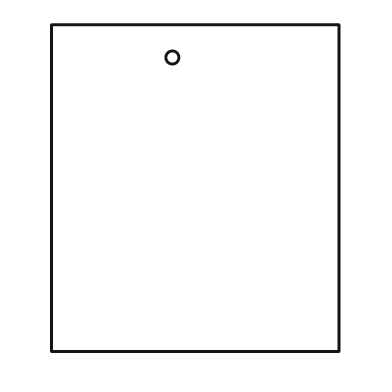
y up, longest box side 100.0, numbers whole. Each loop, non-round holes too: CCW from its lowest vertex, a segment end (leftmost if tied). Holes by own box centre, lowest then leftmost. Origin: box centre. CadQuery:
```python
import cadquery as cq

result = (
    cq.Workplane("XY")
    .moveTo(-44.0, -50.0)
    .lineTo(44.0, -50.0)
    .lineTo(44.0, 50.0)
    .lineTo(-44.0, 50.0)
    .close()
    .moveTo(-7.0, 40.0)
    .circle(2.0)
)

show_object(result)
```